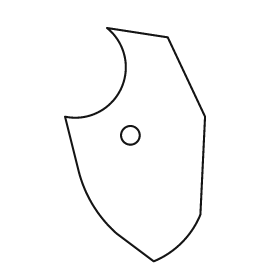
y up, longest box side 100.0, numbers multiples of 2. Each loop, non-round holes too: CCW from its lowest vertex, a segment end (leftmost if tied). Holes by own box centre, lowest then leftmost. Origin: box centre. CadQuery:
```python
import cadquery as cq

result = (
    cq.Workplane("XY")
    .moveTo(8.0, -50.0)
    .threePointArc((20.0, -42.0), (28.0, -30.0))
    .lineTo(30.0, 12.0)
    .lineTo(14.0, 46.0)
    .lineTo(-12.0, 50.0)
    .threePointArc((-6.0, 24.0), (-30.0, 12.0))
    .lineTo(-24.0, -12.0)
    .threePointArc((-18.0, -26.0), (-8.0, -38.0))
    .close()
    .moveTo(-2.0, 4.0)
    .circle(4.0)
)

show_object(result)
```